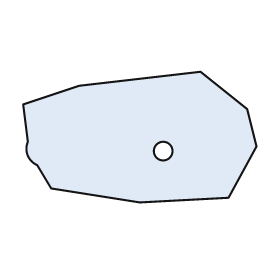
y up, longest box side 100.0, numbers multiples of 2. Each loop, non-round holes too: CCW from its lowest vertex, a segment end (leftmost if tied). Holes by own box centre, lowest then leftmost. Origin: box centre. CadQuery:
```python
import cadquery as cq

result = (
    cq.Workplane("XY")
    .moveTo(0.0, -28.0)
    .lineTo(38.0, -26.0)
    .lineTo(50.0, -4.0)
    .lineTo(46.0, 12.0)
    .lineTo(26.0, 28.0)
    .lineTo(-26.0, 22.0)
    .lineTo(-50.0, 14.0)
    .lineTo(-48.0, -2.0)
    .threePointArc((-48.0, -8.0), (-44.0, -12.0))
    .lineTo(-38.0, -22.0)
    .close()
    .moveTo(10.0, -6.0)
    .circle(4.0)
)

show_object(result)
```